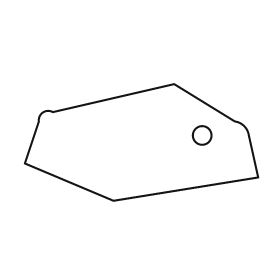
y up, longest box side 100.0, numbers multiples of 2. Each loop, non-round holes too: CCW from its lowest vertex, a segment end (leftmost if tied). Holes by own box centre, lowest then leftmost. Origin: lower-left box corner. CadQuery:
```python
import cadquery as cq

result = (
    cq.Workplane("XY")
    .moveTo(38.0, 0.0)
    .lineTo(100.0, 10.0)
    .lineTo(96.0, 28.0)
    .threePointArc((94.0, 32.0), (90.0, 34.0))
    .lineTo(64.0, 50.0)
    .lineTo(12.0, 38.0)
    .threePointArc((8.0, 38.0), (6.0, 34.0))
    .lineTo(0.0, 16.0)
    .close()
    .moveTo(76.0, 28.0)
    .circle(4.0)
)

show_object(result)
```